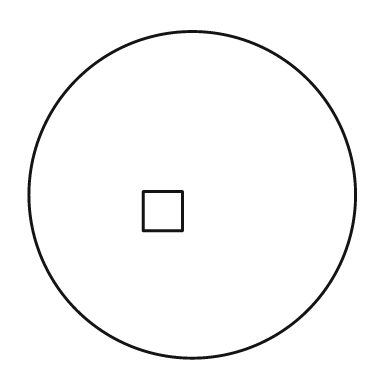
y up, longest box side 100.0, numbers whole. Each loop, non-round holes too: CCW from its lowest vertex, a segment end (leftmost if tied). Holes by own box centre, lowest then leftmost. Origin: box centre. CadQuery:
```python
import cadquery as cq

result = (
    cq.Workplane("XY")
    .moveTo(0.0, 0.0)
    .circle(50.0)
    .moveTo(-15.0, -11.0)
    .lineTo(-3.0, -11.0)
    .lineTo(-3.0, 1.0)
    .lineTo(-15.0, 1.0)
    .close()
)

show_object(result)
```